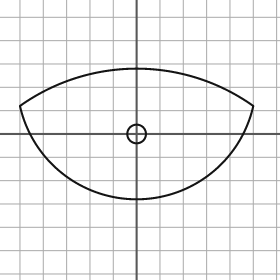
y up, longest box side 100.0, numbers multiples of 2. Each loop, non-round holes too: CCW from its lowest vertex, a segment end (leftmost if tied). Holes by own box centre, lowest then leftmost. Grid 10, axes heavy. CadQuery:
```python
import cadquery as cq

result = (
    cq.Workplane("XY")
    .moveTo(-50.0, 12.0)
    .threePointArc((0.0, -28.0), (50.0, 12.0))
    .threePointArc((0.0, 28.0), (-50.0, 12.0))
    .close()
    .moveTo(0.0, 0.0)
    .circle(4.0)
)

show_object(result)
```